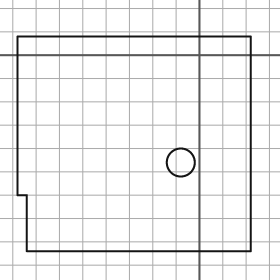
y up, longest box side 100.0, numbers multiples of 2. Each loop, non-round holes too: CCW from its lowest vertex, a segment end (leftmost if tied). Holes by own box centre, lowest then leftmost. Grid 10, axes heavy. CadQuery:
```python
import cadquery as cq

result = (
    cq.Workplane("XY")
    .moveTo(-74.0, -84.0)
    .lineTo(22.0, -84.0)
    .lineTo(22.0, 8.0)
    .lineTo(-78.0, 8.0)
    .lineTo(-78.0, -60.0)
    .lineTo(-74.0, -60.0)
    .close()
    .moveTo(-8.0, -46.0)
    .circle(6.0)
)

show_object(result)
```